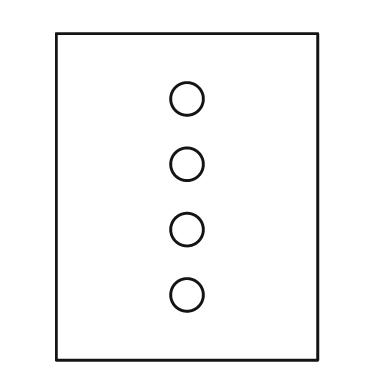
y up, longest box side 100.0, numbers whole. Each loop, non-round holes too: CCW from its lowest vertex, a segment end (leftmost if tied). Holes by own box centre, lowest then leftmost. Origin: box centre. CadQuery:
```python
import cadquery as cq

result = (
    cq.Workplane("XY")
    .moveTo(-40.0, -50.0)
    .lineTo(40.0, -50.0)
    .lineTo(40.0, 50.0)
    .lineTo(-40.0, 50.0)
    .close()
    .moveTo(0.0, -30.0)
    .circle(5.0)
    .moveTo(0.0, -10.0)
    .circle(5.0)
    .moveTo(0.0, 10.0)
    .circle(5.0)
    .moveTo(0.0, 30.0)
    .circle(5.0)
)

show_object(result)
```